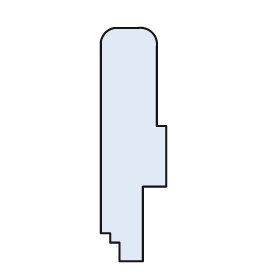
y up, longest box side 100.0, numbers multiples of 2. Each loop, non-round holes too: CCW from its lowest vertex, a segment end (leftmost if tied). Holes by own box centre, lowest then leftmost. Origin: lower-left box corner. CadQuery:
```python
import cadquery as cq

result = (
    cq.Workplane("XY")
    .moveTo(8.0, 0.0)
    .lineTo(18.0, 0.0)
    .lineTo(18.0, 32.0)
    .lineTo(28.0, 32.0)
    .lineTo(28.0, 58.0)
    .lineTo(24.0, 58.0)
    .lineTo(24.0, 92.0)
    .threePointArc((22.0, 98.0), (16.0, 100.0))
    .lineTo(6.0, 100.0)
    .threePointArc((2.0, 98.0), (0.0, 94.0))
    .lineTo(0.0, 12.0)
    .lineTo(4.0, 12.0)
    .lineTo(4.0, 8.0)
    .lineTo(8.0, 8.0)
    .close()
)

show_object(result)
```